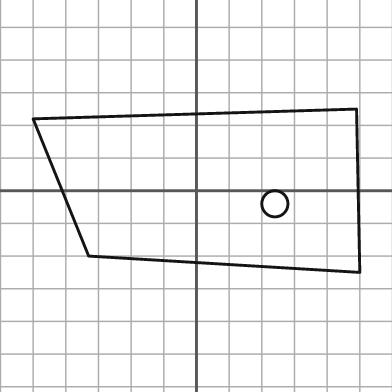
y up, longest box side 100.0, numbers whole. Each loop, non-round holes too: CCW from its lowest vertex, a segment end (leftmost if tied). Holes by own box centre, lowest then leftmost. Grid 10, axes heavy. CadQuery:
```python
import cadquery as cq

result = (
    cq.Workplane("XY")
    .moveTo(50.0, -25.0)
    .lineTo(49.0, 25.0)
    .lineTo(-50.0, 22.0)
    .lineTo(-33.0, -20.0)
    .close()
    .moveTo(24.0, -4.0)
    .circle(4.0)
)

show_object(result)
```